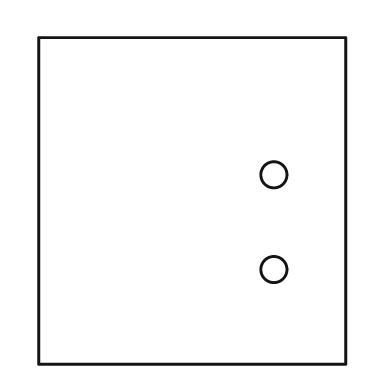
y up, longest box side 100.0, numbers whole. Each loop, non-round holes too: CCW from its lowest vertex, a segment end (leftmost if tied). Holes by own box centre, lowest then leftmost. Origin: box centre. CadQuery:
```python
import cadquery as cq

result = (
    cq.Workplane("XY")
    .moveTo(-47.0, -50.0)
    .lineTo(47.0, -50.0)
    .lineTo(47.0, 50.0)
    .lineTo(-47.0, 50.0)
    .close()
    .moveTo(25.0, -21.0)
    .circle(4.0)
    .moveTo(25.0, 8.0)
    .circle(4.0)
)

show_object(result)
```